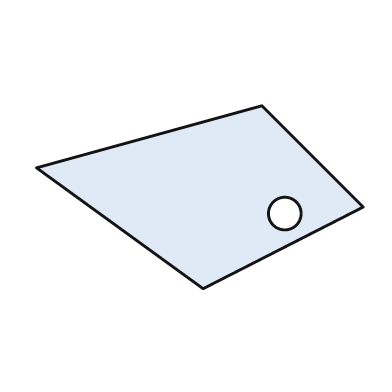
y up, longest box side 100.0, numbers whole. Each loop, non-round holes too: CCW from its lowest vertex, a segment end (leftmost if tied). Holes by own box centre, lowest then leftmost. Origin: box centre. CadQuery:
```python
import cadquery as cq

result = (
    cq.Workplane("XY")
    .moveTo(1.0, -28.0)
    .lineTo(50.0, -3.0)
    .lineTo(19.0, 28.0)
    .lineTo(-50.0, 9.0)
    .close()
    .moveTo(26.0, -5.0)
    .circle(5.0)
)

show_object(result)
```